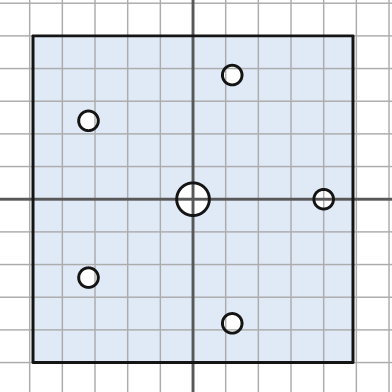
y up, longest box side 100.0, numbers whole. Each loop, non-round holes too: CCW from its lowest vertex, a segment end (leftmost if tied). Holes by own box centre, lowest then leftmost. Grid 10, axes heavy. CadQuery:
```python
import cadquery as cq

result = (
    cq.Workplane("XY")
    .moveTo(-49.0, -50.0)
    .lineTo(49.0, -50.0)
    .lineTo(49.0, 50.0)
    .lineTo(-49.0, 50.0)
    .close()
    .moveTo(12.0, -38.0)
    .circle(3.0)
    .moveTo(-32.0, -24.0)
    .circle(3.0)
    .moveTo(0.0, 0.0)
    .circle(5.0)
    .moveTo(40.0, 0.0)
    .circle(3.0)
    .moveTo(-32.0, 24.0)
    .circle(3.0)
    .moveTo(12.0, 38.0)
    .circle(3.0)
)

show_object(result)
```